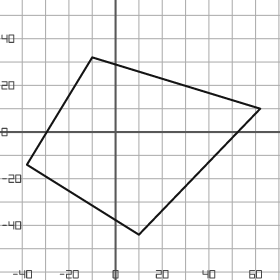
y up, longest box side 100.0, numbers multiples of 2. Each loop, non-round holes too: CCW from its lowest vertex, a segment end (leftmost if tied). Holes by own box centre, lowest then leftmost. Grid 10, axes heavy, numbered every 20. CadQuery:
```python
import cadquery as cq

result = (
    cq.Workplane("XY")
    .moveTo(10.0, -44.0)
    .lineTo(62.0, 10.0)
    .lineTo(-10.0, 32.0)
    .lineTo(-38.0, -14.0)
    .close()
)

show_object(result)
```